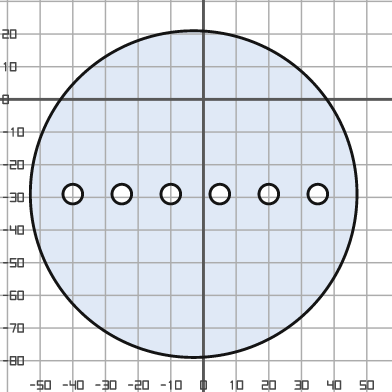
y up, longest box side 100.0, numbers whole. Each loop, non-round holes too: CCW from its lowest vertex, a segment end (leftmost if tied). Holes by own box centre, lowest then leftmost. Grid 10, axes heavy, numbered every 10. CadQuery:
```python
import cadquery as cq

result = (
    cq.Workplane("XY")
    .moveTo(-3.0, -29.0)
    .circle(50.0)
    .moveTo(-40.0, -29.0)
    .circle(3.0)
    .moveTo(-25.0, -29.0)
    .circle(3.0)
    .moveTo(-10.0, -29.0)
    .circle(3.0)
    .moveTo(5.0, -29.0)
    .circle(3.0)
    .moveTo(20.0, -29.0)
    .circle(3.0)
    .moveTo(35.0, -29.0)
    .circle(3.0)
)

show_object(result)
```